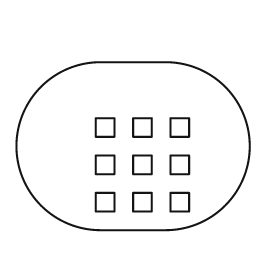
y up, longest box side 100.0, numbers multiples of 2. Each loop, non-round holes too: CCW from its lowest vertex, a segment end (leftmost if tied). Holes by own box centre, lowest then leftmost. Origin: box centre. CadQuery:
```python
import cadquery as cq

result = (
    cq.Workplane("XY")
    .moveTo(-14.0, -36.0)
    .lineTo(14.0, -36.0)
    .threePointArc((50.0, 0.0), (14.0, 36.0))
    .lineTo(-14.0, 36.0)
    .threePointArc((-50.0, 0.0), (-14.0, -36.0))
    .close()
    .moveTo(-16.0, -28.0)
    .lineTo(-8.0, -28.0)
    .lineTo(-8.0, -20.0)
    .lineTo(-16.0, -20.0)
    .close()
    .moveTo(0.0, -28.0)
    .lineTo(8.0, -28.0)
    .lineTo(8.0, -20.0)
    .lineTo(0.0, -20.0)
    .close()
    .moveTo(16.0, -28.0)
    .lineTo(24.0, -28.0)
    .lineTo(24.0, -20.0)
    .lineTo(16.0, -20.0)
    .close()
    .moveTo(-16.0, -12.0)
    .lineTo(-8.0, -12.0)
    .lineTo(-8.0, -4.0)
    .lineTo(-16.0, -4.0)
    .close()
    .moveTo(0.0, -12.0)
    .lineTo(8.0, -12.0)
    .lineTo(8.0, -4.0)
    .lineTo(0.0, -4.0)
    .close()
    .moveTo(16.0, -12.0)
    .lineTo(24.0, -12.0)
    .lineTo(24.0, -4.0)
    .lineTo(16.0, -4.0)
    .close()
    .moveTo(-16.0, 4.0)
    .lineTo(-8.0, 4.0)
    .lineTo(-8.0, 12.0)
    .lineTo(-16.0, 12.0)
    .close()
    .moveTo(0.0, 4.0)
    .lineTo(8.0, 4.0)
    .lineTo(8.0, 12.0)
    .lineTo(0.0, 12.0)
    .close()
    .moveTo(16.0, 4.0)
    .lineTo(24.0, 4.0)
    .lineTo(24.0, 12.0)
    .lineTo(16.0, 12.0)
    .close()
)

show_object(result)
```